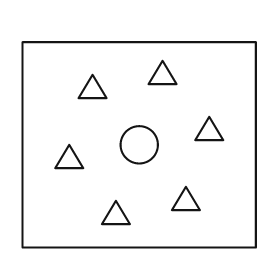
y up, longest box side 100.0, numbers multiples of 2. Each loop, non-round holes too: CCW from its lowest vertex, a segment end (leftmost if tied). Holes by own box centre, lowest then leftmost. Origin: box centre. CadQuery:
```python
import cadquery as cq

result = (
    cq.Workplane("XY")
    .moveTo(-50.0, -44.0)
    .lineTo(50.0, -44.0)
    .lineTo(50.0, 44.0)
    .lineTo(-50.0, 44.0)
    .close()
    .moveTo(-16.0, -34.0)
    .lineTo(-4.0, -34.0)
    .lineTo(-10.0, -24.0)
    .close()
    .moveTo(14.0, -28.0)
    .lineTo(26.0, -28.0)
    .lineTo(20.0, -18.0)
    .close()
    .moveTo(-36.0, -10.0)
    .lineTo(-24.0, -10.0)
    .lineTo(-30.0, 0.0)
    .close()
    .moveTo(0.0, 0.0)
    .circle(8.0)
    .moveTo(24.0, 2.0)
    .lineTo(36.0, 2.0)
    .lineTo(30.0, 12.0)
    .close()
    .moveTo(-26.0, 20.0)
    .lineTo(-14.0, 20.0)
    .lineTo(-20.0, 30.0)
    .close()
    .moveTo(4.0, 26.0)
    .lineTo(16.0, 26.0)
    .lineTo(10.0, 36.0)
    .close()
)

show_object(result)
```